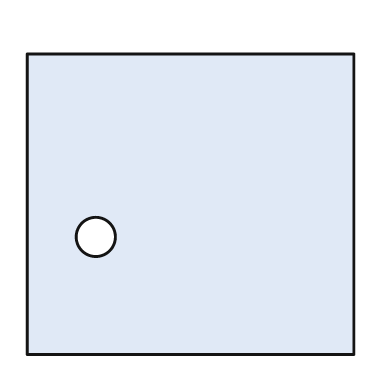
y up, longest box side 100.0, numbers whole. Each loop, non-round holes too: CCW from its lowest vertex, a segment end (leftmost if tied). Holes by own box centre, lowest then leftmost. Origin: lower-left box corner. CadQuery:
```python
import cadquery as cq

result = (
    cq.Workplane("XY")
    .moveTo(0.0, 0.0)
    .lineTo(100.0, 0.0)
    .lineTo(100.0, 92.0)
    .lineTo(0.0, 92.0)
    .close()
    .moveTo(21.0, 36.0)
    .circle(6.0)
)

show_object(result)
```